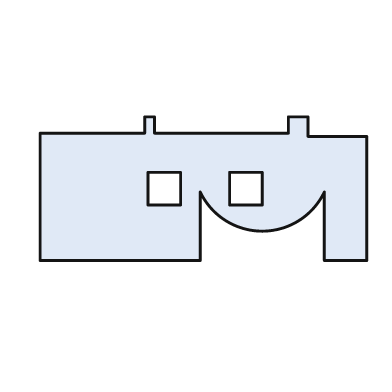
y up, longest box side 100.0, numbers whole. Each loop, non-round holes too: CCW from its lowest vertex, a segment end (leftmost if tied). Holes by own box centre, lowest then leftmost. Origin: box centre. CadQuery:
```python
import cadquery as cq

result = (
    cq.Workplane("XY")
    .moveTo(-50.0, -22.0)
    .lineTo(-1.0, -22.0)
    .lineTo(-1.0, -1.0)
    .threePointArc((18.0, -13.0), (37.0, -1.0))
    .lineTo(37.0, -22.0)
    .lineTo(50.0, -22.0)
    .lineTo(50.0, 16.0)
    .lineTo(32.0, 16.0)
    .lineTo(32.0, 22.0)
    .lineTo(26.0, 22.0)
    .lineTo(26.0, 17.0)
    .lineTo(-15.0, 17.0)
    .lineTo(-15.0, 22.0)
    .lineTo(-18.0, 22.0)
    .lineTo(-18.0, 17.0)
    .lineTo(-50.0, 17.0)
    .close()
    .moveTo(-17.0, -5.0)
    .lineTo(-7.0, -5.0)
    .lineTo(-7.0, 5.0)
    .lineTo(-17.0, 5.0)
    .close()
    .moveTo(8.0, -5.0)
    .lineTo(18.0, -5.0)
    .lineTo(18.0, 5.0)
    .lineTo(8.0, 5.0)
    .close()
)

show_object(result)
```